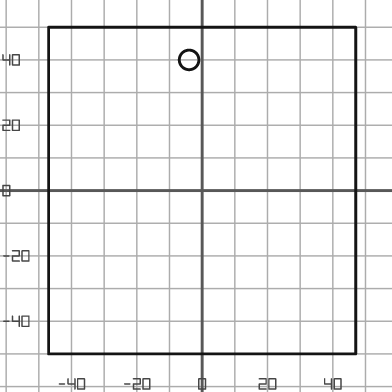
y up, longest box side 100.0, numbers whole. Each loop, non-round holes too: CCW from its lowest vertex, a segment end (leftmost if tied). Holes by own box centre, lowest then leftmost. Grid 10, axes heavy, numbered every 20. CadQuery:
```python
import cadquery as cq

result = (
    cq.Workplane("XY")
    .moveTo(-47.0, -50.0)
    .lineTo(47.0, -50.0)
    .lineTo(47.0, 50.0)
    .lineTo(-47.0, 50.0)
    .close()
    .moveTo(-4.0, 40.0)
    .circle(3.0)
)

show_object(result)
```